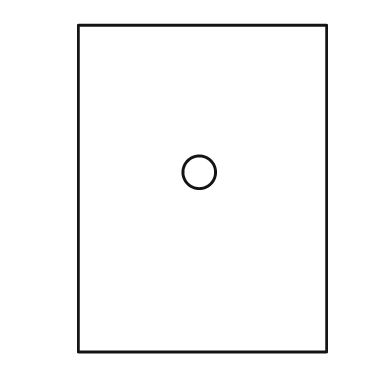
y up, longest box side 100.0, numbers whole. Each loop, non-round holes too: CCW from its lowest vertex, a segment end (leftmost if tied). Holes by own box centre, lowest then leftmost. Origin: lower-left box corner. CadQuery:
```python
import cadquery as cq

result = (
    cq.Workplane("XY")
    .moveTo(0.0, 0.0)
    .lineTo(76.0, 0.0)
    .lineTo(76.0, 100.0)
    .lineTo(0.0, 100.0)
    .close()
    .moveTo(37.0, 55.0)
    .circle(5.0)
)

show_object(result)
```